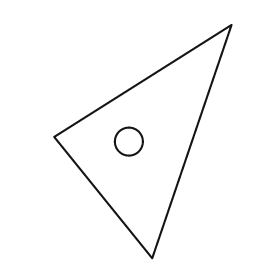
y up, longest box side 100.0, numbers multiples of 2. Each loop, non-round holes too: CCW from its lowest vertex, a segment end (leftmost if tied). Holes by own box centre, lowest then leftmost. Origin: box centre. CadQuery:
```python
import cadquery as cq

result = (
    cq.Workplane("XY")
    .moveTo(4.0, -50.0)
    .lineTo(38.0, 50.0)
    .lineTo(-38.0, 2.0)
    .close()
    .moveTo(-6.0, 0.0)
    .circle(6.0)
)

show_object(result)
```